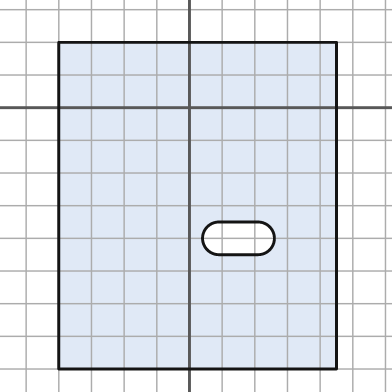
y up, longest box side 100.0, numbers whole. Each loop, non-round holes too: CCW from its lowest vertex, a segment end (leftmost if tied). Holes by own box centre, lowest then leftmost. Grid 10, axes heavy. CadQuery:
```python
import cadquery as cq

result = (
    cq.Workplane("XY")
    .moveTo(-40.0, -80.0)
    .lineTo(45.0, -80.0)
    .lineTo(45.0, 20.0)
    .lineTo(-40.0, 20.0)
    .close()
    .moveTo(9.0, -45.0)
    .lineTo(21.0, -45.0)
    .threePointArc((26.0, -40.0), (21.0, -35.0))
    .lineTo(9.0, -35.0)
    .threePointArc((4.0, -40.0), (9.0, -45.0))
    .close()
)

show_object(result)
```